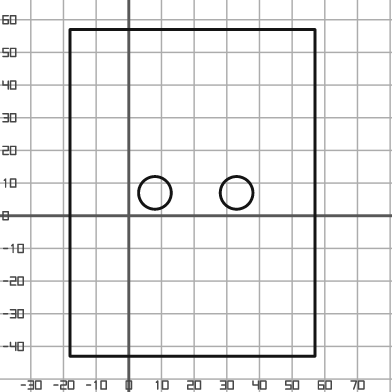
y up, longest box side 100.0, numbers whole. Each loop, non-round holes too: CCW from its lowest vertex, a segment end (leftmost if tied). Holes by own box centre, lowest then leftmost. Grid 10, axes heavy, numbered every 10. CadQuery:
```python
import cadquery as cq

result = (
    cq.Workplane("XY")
    .moveTo(-18.0, -43.0)
    .lineTo(57.0, -43.0)
    .lineTo(57.0, 57.0)
    .lineTo(-18.0, 57.0)
    .close()
    .moveTo(8.0, 7.0)
    .circle(5.0)
    .moveTo(33.0, 7.0)
    .circle(5.0)
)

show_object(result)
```